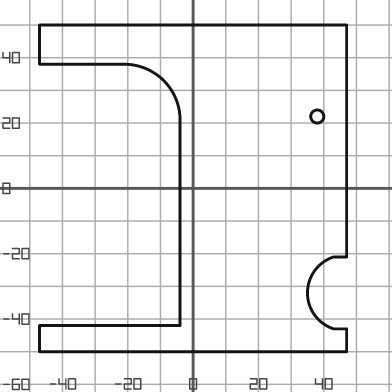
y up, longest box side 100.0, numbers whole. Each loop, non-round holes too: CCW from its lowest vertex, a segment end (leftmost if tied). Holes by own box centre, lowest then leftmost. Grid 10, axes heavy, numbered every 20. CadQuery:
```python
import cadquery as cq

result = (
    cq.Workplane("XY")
    .moveTo(-47.0, -50.0)
    .lineTo(47.0, -50.0)
    .lineTo(47.0, -43.0)
    .lineTo(43.0, -43.0)
    .threePointArc((35.0, -32.0), (43.0, -21.0))
    .lineTo(47.0, -21.0)
    .lineTo(47.0, 50.0)
    .lineTo(-47.0, 50.0)
    .lineTo(-47.0, 38.0)
    .lineTo(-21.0, 38.0)
    .threePointArc((-9.0, 33.0), (-4.0, 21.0))
    .lineTo(-4.0, -42.0)
    .lineTo(-47.0, -42.0)
    .close()
    .moveTo(38.0, 22.0)
    .circle(2.0)
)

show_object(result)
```